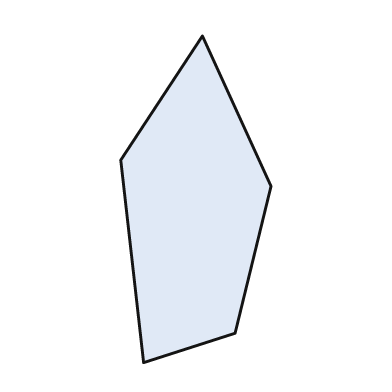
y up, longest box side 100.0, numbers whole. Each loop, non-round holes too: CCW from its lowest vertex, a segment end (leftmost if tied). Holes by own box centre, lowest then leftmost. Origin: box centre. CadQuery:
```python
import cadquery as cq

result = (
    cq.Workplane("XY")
    .moveTo(-16.0, -50.0)
    .lineTo(12.0, -41.0)
    .lineTo(23.0, 4.0)
    .lineTo(2.0, 50.0)
    .lineTo(-23.0, 12.0)
    .close()
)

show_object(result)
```